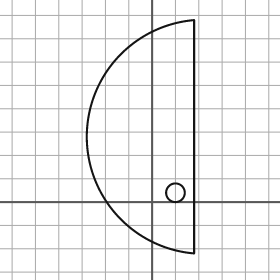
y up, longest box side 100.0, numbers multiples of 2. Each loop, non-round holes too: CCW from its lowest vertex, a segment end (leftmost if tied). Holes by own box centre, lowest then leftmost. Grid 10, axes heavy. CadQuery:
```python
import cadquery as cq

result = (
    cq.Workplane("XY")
    .moveTo(18.0, -22.0)
    .lineTo(18.0, 78.0)
    .threePointArc((-28.0, 28.0), (18.0, -22.0))
    .close()
    .moveTo(10.0, 4.0)
    .circle(4.0)
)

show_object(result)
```